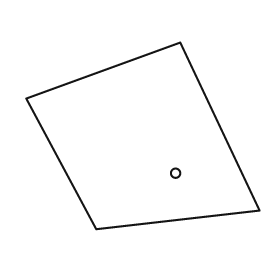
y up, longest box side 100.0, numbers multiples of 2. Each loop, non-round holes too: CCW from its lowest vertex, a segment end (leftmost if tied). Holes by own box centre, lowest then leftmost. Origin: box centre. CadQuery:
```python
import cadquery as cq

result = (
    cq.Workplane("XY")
    .moveTo(-20.0, -40.0)
    .lineTo(50.0, -32.0)
    .lineTo(16.0, 40.0)
    .lineTo(-50.0, 16.0)
    .close()
    .moveTo(14.0, -16.0)
    .circle(2.0)
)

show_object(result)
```